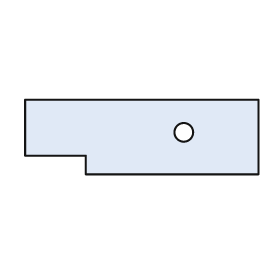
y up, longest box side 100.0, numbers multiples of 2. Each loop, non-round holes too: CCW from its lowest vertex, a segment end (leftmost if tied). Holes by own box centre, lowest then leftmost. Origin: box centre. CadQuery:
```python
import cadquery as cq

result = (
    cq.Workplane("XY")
    .moveTo(-24.0, -16.0)
    .lineTo(50.0, -16.0)
    .lineTo(50.0, 16.0)
    .lineTo(-50.0, 16.0)
    .lineTo(-50.0, -8.0)
    .lineTo(-24.0, -8.0)
    .close()
    .moveTo(18.0, 2.0)
    .circle(4.0)
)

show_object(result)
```